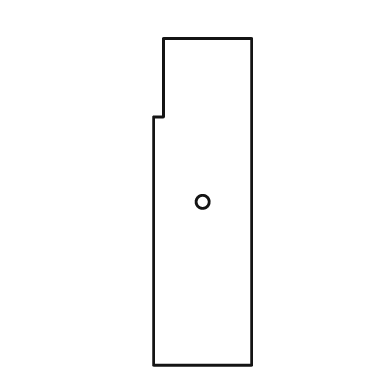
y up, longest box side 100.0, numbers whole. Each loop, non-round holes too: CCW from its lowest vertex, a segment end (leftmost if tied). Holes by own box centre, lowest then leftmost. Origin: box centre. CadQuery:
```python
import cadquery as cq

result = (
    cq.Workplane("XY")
    .moveTo(-15.0, -50.0)
    .lineTo(15.0, -50.0)
    .lineTo(15.0, 50.0)
    .lineTo(-12.0, 50.0)
    .lineTo(-12.0, 26.0)
    .lineTo(-15.0, 26.0)
    .close()
    .moveTo(0.0, 0.0)
    .circle(2.0)
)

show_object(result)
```